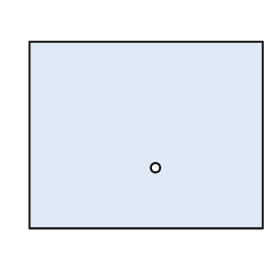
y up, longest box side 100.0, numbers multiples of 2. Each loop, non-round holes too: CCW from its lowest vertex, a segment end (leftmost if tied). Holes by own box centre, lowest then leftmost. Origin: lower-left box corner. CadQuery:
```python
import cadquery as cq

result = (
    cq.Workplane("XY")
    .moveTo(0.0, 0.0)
    .lineTo(100.0, 0.0)
    .lineTo(100.0, 80.0)
    .lineTo(0.0, 80.0)
    .close()
    .moveTo(54.0, 26.0)
    .circle(2.0)
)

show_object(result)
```